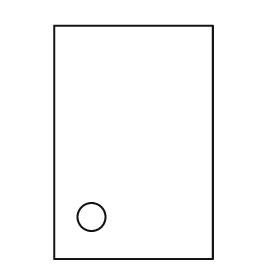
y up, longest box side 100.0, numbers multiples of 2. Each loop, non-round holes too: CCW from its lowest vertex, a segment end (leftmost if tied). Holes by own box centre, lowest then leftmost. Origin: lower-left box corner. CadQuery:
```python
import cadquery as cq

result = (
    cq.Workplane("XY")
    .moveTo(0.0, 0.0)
    .lineTo(68.0, 0.0)
    .lineTo(68.0, 100.0)
    .lineTo(0.0, 100.0)
    .close()
    .moveTo(16.0, 18.0)
    .circle(6.0)
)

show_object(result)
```